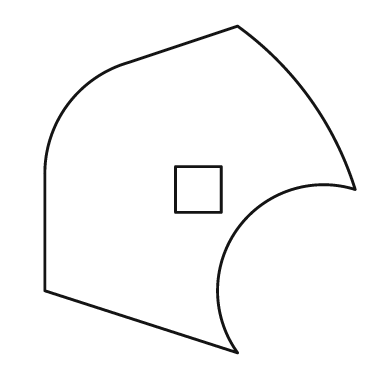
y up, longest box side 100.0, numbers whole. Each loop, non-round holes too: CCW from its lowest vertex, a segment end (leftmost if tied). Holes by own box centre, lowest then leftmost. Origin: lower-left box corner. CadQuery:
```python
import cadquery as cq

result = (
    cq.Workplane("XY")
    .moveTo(59.0, 0.0)
    .threePointArc((59.0, 38.0), (95.0, 50.0))
    .threePointArc((81.0, 78.0), (59.0, 100.0))
    .lineTo(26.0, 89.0)
    .threePointArc((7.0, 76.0), (0.0, 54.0))
    .lineTo(0.0, 19.0)
    .close()
    .moveTo(40.0, 43.0)
    .lineTo(54.0, 43.0)
    .lineTo(54.0, 57.0)
    .lineTo(40.0, 57.0)
    .close()
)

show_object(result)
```